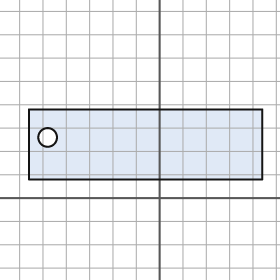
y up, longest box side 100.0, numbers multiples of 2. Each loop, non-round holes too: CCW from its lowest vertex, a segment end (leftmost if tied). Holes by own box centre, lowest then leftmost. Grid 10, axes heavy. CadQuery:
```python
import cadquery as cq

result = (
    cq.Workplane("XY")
    .moveTo(-56.0, 8.0)
    .lineTo(44.0, 8.0)
    .lineTo(44.0, 38.0)
    .lineTo(-56.0, 38.0)
    .close()
    .moveTo(-48.0, 26.0)
    .circle(4.0)
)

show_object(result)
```